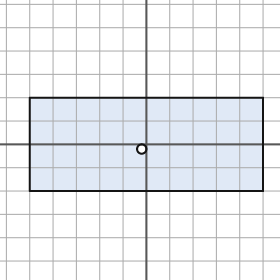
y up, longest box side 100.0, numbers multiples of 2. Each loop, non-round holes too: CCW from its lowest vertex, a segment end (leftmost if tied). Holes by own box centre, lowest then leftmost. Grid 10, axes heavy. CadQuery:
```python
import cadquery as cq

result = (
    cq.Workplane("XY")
    .moveTo(-50.0, -20.0)
    .lineTo(50.0, -20.0)
    .lineTo(50.0, 20.0)
    .lineTo(-50.0, 20.0)
    .close()
    .moveTo(-2.0, -2.0)
    .circle(2.0)
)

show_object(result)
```